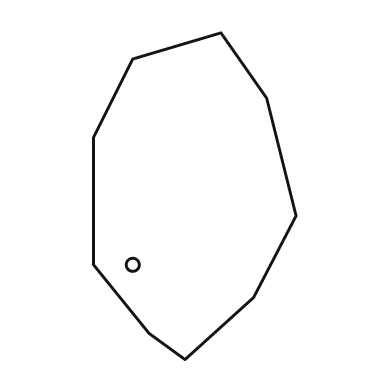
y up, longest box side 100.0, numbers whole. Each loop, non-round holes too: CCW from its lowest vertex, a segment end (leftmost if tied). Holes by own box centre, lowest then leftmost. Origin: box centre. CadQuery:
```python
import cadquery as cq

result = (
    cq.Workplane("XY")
    .moveTo(-3.0, -50.0)
    .lineTo(18.0, -31.0)
    .lineTo(31.0, -6.0)
    .lineTo(22.0, 30.0)
    .lineTo(8.0, 50.0)
    .lineTo(-19.0, 42.0)
    .lineTo(-31.0, 18.0)
    .lineTo(-31.0, -21.0)
    .lineTo(-14.0, -42.0)
    .close()
    .moveTo(-19.0, -21.0)
    .circle(2.0)
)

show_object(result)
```